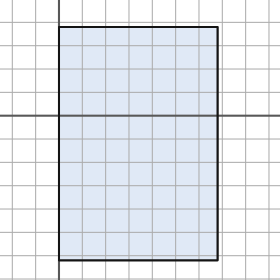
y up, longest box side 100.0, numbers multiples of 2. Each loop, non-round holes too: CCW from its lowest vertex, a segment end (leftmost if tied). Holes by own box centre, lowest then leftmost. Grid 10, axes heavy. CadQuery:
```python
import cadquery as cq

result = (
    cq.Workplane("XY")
    .moveTo(0.0, -62.0)
    .lineTo(68.0, -62.0)
    .lineTo(68.0, 38.0)
    .lineTo(0.0, 38.0)
    .close()
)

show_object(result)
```